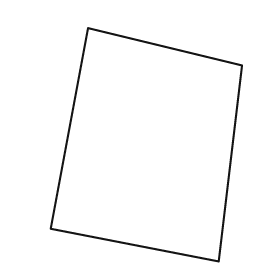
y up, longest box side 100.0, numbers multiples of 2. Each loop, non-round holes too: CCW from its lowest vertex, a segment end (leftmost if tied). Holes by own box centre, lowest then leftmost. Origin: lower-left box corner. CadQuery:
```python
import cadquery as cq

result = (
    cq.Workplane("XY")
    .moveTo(72.0, 0.0)
    .lineTo(82.0, 84.0)
    .lineTo(16.0, 100.0)
    .lineTo(0.0, 14.0)
    .close()
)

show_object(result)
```